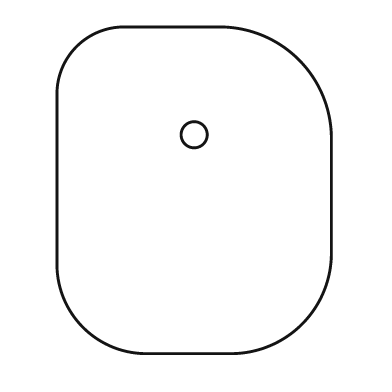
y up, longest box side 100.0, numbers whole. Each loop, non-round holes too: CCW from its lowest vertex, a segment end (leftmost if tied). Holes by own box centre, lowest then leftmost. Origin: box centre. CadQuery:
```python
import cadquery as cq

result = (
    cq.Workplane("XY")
    .moveTo(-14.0, -50.0)
    .lineTo(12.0, -50.0)
    .threePointArc((33.0, -41.0), (42.0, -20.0))
    .lineTo(42.0, 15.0)
    .threePointArc((32.0, 40.0), (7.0, 50.0))
    .lineTo(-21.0, 50.0)
    .threePointArc((-36.0, 44.0), (-42.0, 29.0))
    .lineTo(-42.0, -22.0)
    .threePointArc((-34.0, -42.0), (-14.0, -50.0))
    .close()
    .moveTo(0.0, 17.0)
    .circle(4.0)
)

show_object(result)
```